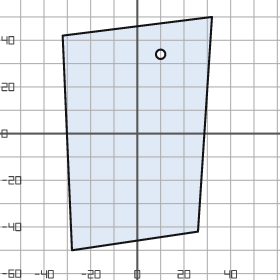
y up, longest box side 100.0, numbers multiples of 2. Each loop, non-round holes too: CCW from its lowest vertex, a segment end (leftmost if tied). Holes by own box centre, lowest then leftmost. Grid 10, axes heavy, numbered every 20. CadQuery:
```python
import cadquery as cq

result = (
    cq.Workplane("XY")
    .moveTo(-28.0, -50.0)
    .lineTo(26.0, -42.0)
    .lineTo(32.0, 50.0)
    .lineTo(-32.0, 42.0)
    .close()
    .moveTo(10.0, 34.0)
    .circle(2.0)
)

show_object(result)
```